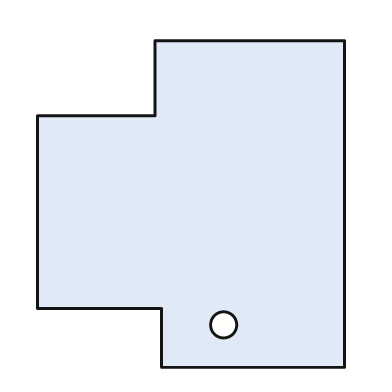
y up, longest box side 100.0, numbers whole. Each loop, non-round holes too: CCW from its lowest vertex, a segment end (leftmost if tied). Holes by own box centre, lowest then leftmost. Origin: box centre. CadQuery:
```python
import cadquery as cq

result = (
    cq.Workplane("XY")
    .moveTo(-9.0, -50.0)
    .lineTo(47.0, -50.0)
    .lineTo(47.0, 50.0)
    .lineTo(-11.0, 50.0)
    .lineTo(-11.0, 27.0)
    .lineTo(-47.0, 27.0)
    .lineTo(-47.0, -32.0)
    .lineTo(-9.0, -32.0)
    .close()
    .moveTo(10.0, -37.0)
    .circle(4.0)
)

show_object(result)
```